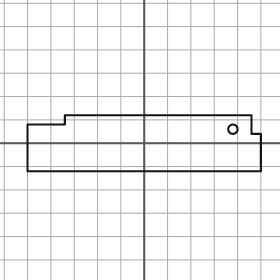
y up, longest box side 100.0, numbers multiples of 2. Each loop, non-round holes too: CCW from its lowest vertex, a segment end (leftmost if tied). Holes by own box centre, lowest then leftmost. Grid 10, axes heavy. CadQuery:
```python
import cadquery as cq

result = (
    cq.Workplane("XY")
    .moveTo(-50.0, -12.0)
    .lineTo(50.0, -12.0)
    .lineTo(50.0, 4.0)
    .lineTo(46.0, 4.0)
    .lineTo(46.0, 12.0)
    .lineTo(-34.0, 12.0)
    .lineTo(-34.0, 8.0)
    .lineTo(-50.0, 8.0)
    .close()
    .moveTo(38.0, 6.0)
    .circle(2.0)
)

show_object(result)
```